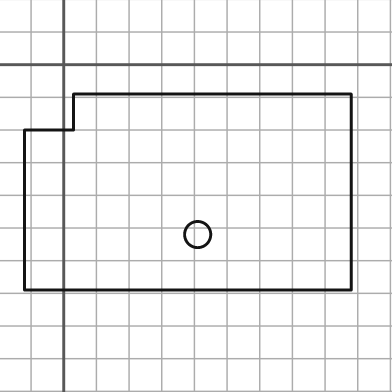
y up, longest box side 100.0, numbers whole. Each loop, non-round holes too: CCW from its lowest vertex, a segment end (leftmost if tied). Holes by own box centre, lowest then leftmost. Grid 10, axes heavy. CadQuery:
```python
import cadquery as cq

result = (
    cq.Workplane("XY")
    .moveTo(-12.0, -69.0)
    .lineTo(88.0, -69.0)
    .lineTo(88.0, -9.0)
    .lineTo(3.0, -9.0)
    .lineTo(3.0, -20.0)
    .lineTo(-12.0, -20.0)
    .close()
    .moveTo(41.0, -52.0)
    .circle(4.0)
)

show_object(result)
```